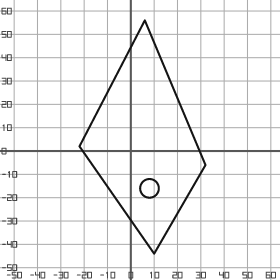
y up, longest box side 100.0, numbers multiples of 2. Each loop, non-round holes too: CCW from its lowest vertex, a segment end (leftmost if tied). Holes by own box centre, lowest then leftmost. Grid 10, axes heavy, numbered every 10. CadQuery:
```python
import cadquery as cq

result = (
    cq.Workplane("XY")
    .moveTo(10.0, -44.0)
    .lineTo(32.0, -6.0)
    .lineTo(6.0, 56.0)
    .lineTo(-22.0, 2.0)
    .close()
    .moveTo(8.0, -16.0)
    .circle(4.0)
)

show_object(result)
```